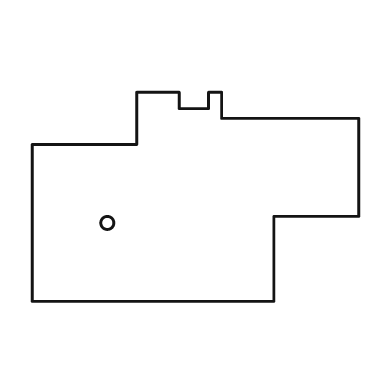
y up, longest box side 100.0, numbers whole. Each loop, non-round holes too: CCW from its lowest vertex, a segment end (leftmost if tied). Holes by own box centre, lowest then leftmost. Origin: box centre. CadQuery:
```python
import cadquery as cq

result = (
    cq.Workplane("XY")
    .moveTo(-50.0, -32.0)
    .lineTo(24.0, -32.0)
    .lineTo(24.0, -6.0)
    .lineTo(50.0, -6.0)
    .lineTo(50.0, 24.0)
    .lineTo(8.0, 24.0)
    .lineTo(8.0, 32.0)
    .lineTo(4.0, 32.0)
    .lineTo(4.0, 27.0)
    .lineTo(-5.0, 27.0)
    .lineTo(-5.0, 32.0)
    .lineTo(-18.0, 32.0)
    .lineTo(-18.0, 16.0)
    .lineTo(-50.0, 16.0)
    .close()
    .moveTo(-27.0, -8.0)
    .circle(2.0)
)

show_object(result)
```